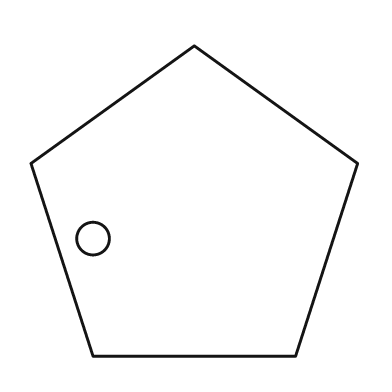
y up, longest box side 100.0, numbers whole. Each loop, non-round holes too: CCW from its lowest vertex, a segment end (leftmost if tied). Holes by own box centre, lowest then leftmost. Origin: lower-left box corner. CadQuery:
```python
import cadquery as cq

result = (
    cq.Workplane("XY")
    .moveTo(19.0, 0.0)
    .lineTo(81.0, 0.0)
    .lineTo(100.0, 59.0)
    .lineTo(50.0, 95.0)
    .lineTo(0.0, 59.0)
    .close()
    .moveTo(19.0, 36.0)
    .circle(5.0)
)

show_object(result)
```